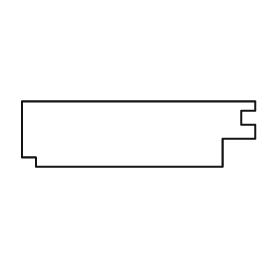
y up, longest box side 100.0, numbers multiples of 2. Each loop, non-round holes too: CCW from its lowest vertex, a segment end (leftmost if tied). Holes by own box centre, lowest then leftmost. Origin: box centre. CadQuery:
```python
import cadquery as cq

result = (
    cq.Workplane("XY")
    .moveTo(-44.0, -14.0)
    .lineTo(36.0, -14.0)
    .lineTo(36.0, -2.0)
    .lineTo(50.0, -2.0)
    .lineTo(50.0, 4.0)
    .lineTo(44.0, 4.0)
    .lineTo(44.0, 10.0)
    .lineTo(50.0, 10.0)
    .lineTo(50.0, 14.0)
    .lineTo(-50.0, 14.0)
    .lineTo(-50.0, -10.0)
    .lineTo(-44.0, -10.0)
    .close()
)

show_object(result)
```